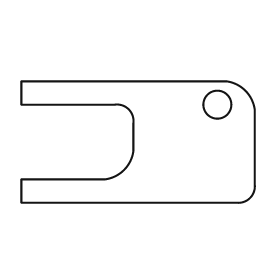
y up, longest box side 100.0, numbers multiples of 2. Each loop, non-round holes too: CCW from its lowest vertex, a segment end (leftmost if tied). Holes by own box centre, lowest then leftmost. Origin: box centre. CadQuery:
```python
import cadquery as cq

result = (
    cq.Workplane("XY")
    .moveTo(-50.0, -26.0)
    .lineTo(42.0, -26.0)
    .threePointArc((48.0, -24.0), (50.0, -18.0))
    .lineTo(50.0, 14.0)
    .threePointArc((46.0, 22.0), (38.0, 26.0))
    .lineTo(-50.0, 26.0)
    .lineTo(-50.0, 16.0)
    .lineTo(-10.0, 16.0)
    .threePointArc((-4.0, 14.0), (-2.0, 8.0))
    .lineTo(-2.0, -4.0)
    .threePointArc((-6.0, -12.0), (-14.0, -16.0))
    .lineTo(-50.0, -16.0)
    .close()
    .moveTo(34.0, 16.0)
    .circle(6.0)
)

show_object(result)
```